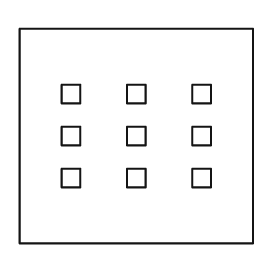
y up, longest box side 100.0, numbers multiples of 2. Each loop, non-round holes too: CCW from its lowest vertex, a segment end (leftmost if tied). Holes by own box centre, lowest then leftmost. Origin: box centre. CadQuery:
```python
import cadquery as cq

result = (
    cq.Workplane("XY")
    .moveTo(-50.0, -46.0)
    .lineTo(50.0, -46.0)
    .lineTo(50.0, 46.0)
    .lineTo(-50.0, 46.0)
    .close()
    .moveTo(-32.0, -22.0)
    .lineTo(-24.0, -22.0)
    .lineTo(-24.0, -14.0)
    .lineTo(-32.0, -14.0)
    .close()
    .moveTo(-4.0, -22.0)
    .lineTo(4.0, -22.0)
    .lineTo(4.0, -14.0)
    .lineTo(-4.0, -14.0)
    .close()
    .moveTo(24.0, -22.0)
    .lineTo(32.0, -22.0)
    .lineTo(32.0, -14.0)
    .lineTo(24.0, -14.0)
    .close()
    .moveTo(-32.0, -4.0)
    .lineTo(-24.0, -4.0)
    .lineTo(-24.0, 4.0)
    .lineTo(-32.0, 4.0)
    .close()
    .moveTo(-4.0, -4.0)
    .lineTo(4.0, -4.0)
    .lineTo(4.0, 4.0)
    .lineTo(-4.0, 4.0)
    .close()
    .moveTo(24.0, -4.0)
    .lineTo(32.0, -4.0)
    .lineTo(32.0, 4.0)
    .lineTo(24.0, 4.0)
    .close()
    .moveTo(-32.0, 14.0)
    .lineTo(-24.0, 14.0)
    .lineTo(-24.0, 22.0)
    .lineTo(-32.0, 22.0)
    .close()
    .moveTo(-4.0, 14.0)
    .lineTo(4.0, 14.0)
    .lineTo(4.0, 22.0)
    .lineTo(-4.0, 22.0)
    .close()
    .moveTo(24.0, 14.0)
    .lineTo(32.0, 14.0)
    .lineTo(32.0, 22.0)
    .lineTo(24.0, 22.0)
    .close()
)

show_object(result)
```